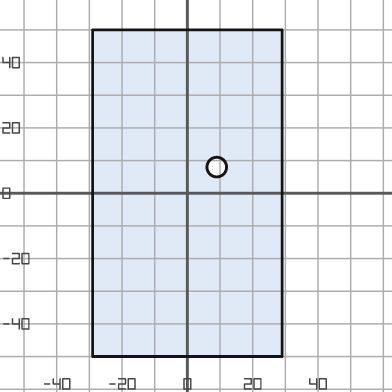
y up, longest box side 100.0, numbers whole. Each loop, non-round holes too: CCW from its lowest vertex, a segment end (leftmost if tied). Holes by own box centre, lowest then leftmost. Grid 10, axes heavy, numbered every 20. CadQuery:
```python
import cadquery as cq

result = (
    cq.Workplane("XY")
    .moveTo(-29.0, -50.0)
    .lineTo(29.0, -50.0)
    .lineTo(29.0, 50.0)
    .lineTo(-29.0, 50.0)
    .close()
    .moveTo(9.0, 8.0)
    .circle(3.0)
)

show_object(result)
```